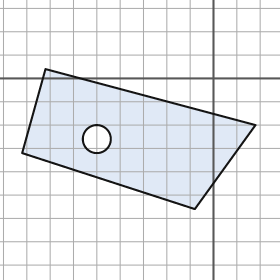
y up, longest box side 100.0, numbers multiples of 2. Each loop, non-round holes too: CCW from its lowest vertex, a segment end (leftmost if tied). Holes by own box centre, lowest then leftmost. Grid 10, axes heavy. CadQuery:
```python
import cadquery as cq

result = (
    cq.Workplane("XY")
    .moveTo(-8.0, -56.0)
    .lineTo(18.0, -20.0)
    .lineTo(-72.0, 4.0)
    .lineTo(-82.0, -32.0)
    .close()
    .moveTo(-50.0, -26.0)
    .circle(6.0)
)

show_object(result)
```